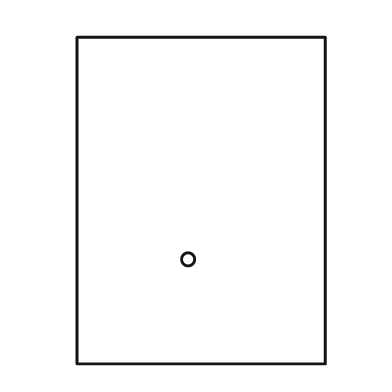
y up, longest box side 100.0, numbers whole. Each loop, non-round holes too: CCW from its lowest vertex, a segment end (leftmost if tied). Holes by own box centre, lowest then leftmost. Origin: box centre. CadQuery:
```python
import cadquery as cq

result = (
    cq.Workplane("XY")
    .moveTo(-38.0, -50.0)
    .lineTo(38.0, -50.0)
    .lineTo(38.0, 50.0)
    .lineTo(-38.0, 50.0)
    .close()
    .moveTo(-4.0, -18.0)
    .circle(2.0)
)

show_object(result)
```